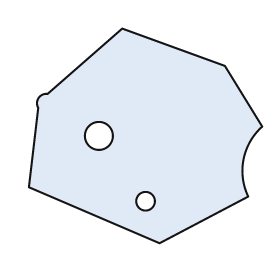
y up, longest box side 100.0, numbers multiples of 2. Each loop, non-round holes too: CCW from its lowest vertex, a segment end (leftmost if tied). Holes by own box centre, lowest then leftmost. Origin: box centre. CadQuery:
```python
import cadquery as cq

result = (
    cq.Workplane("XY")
    .moveTo(6.0, -46.0)
    .lineTo(44.0, -26.0)
    .threePointArc((42.0, -10.0), (50.0, 4.0))
    .lineTo(34.0, 30.0)
    .lineTo(-10.0, 46.0)
    .lineTo(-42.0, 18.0)
    .threePointArc((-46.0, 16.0), (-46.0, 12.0))
    .lineTo(-50.0, -22.0)
    .close()
    .moveTo(0.0, -28.0)
    .circle(4.0)
    .moveTo(-20.0, 0.0)
    .circle(6.0)
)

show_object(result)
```